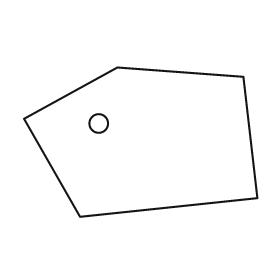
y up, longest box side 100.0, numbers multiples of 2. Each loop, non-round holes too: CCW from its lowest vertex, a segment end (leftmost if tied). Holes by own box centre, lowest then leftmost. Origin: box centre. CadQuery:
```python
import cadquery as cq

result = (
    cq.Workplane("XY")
    .moveTo(-26.0, -32.0)
    .lineTo(50.0, -24.0)
    .lineTo(44.0, 28.0)
    .lineTo(-10.0, 32.0)
    .lineTo(-50.0, 10.0)
    .close()
    .moveTo(-18.0, 8.0)
    .circle(4.0)
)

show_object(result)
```